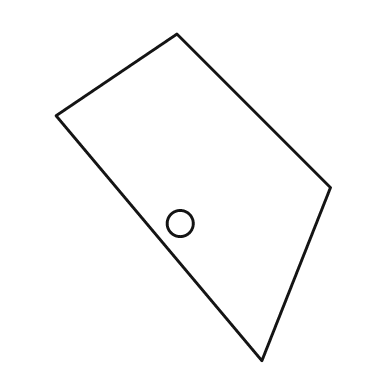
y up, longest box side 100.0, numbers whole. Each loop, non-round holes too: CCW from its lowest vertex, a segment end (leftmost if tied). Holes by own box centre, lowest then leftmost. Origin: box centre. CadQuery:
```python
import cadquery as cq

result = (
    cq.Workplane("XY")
    .moveTo(21.0, -50.0)
    .lineTo(42.0, 3.0)
    .lineTo(-5.0, 50.0)
    .lineTo(-42.0, 25.0)
    .close()
    .moveTo(-4.0, -8.0)
    .circle(4.0)
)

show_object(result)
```